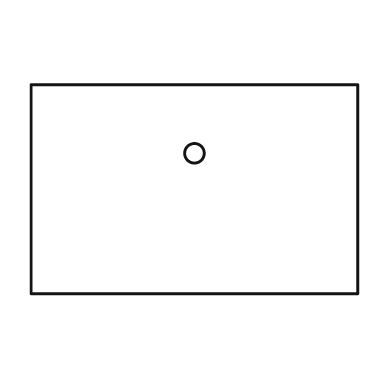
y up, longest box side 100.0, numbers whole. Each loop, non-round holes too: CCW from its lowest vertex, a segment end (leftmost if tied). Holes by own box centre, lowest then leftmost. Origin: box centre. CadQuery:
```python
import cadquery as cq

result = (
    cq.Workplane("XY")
    .moveTo(-50.0, -32.0)
    .lineTo(50.0, -32.0)
    .lineTo(50.0, 32.0)
    .lineTo(-50.0, 32.0)
    .close()
    .moveTo(0.0, 11.0)
    .circle(3.0)
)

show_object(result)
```